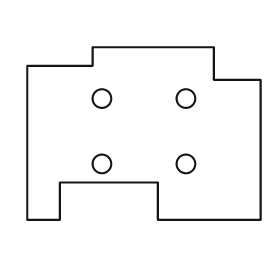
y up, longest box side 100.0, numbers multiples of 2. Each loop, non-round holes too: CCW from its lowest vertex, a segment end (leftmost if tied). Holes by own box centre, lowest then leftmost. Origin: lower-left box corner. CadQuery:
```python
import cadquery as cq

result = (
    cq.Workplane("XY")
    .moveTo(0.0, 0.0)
    .lineTo(14.0, 0.0)
    .lineTo(14.0, 16.0)
    .lineTo(56.0, 16.0)
    .lineTo(56.0, 0.0)
    .lineTo(100.0, 0.0)
    .lineTo(100.0, 60.0)
    .lineTo(80.0, 60.0)
    .lineTo(80.0, 74.0)
    .lineTo(28.0, 74.0)
    .lineTo(28.0, 66.0)
    .lineTo(0.0, 66.0)
    .close()
    .moveTo(32.0, 24.0)
    .circle(4.0)
    .moveTo(68.0, 24.0)
    .circle(4.0)
    .moveTo(32.0, 52.0)
    .circle(4.0)
    .moveTo(68.0, 52.0)
    .circle(4.0)
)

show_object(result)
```